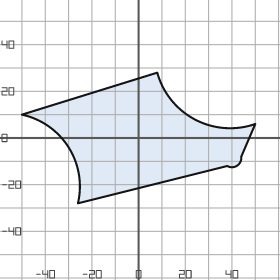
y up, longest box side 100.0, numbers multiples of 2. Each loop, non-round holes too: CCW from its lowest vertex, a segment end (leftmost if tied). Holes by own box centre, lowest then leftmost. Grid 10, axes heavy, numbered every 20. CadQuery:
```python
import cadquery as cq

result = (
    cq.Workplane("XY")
    .moveTo(-26.0, -28.0)
    .lineTo(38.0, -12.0)
    .threePointArc((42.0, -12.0), (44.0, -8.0))
    .lineTo(50.0, 6.0)
    .threePointArc((24.0, 8.0), (8.0, 28.0))
    .lineTo(-50.0, 10.0)
    .threePointArc((-30.0, -4.0), (-26.0, -28.0))
    .close()
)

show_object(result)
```